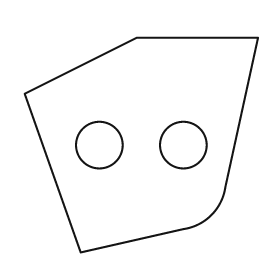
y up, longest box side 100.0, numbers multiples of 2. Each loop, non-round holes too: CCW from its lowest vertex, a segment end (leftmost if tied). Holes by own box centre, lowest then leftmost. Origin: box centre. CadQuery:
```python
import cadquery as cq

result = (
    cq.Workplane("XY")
    .moveTo(-26.0, -46.0)
    .lineTo(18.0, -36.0)
    .threePointArc((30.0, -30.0), (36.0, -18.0))
    .lineTo(50.0, 46.0)
    .lineTo(-2.0, 46.0)
    .lineTo(-50.0, 22.0)
    .close()
    .moveTo(-18.0, 0.0)
    .circle(10.0)
    .moveTo(18.0, 0.0)
    .circle(10.0)
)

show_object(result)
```